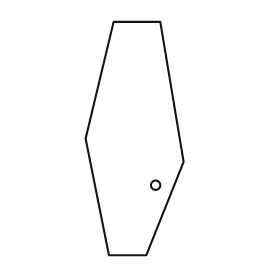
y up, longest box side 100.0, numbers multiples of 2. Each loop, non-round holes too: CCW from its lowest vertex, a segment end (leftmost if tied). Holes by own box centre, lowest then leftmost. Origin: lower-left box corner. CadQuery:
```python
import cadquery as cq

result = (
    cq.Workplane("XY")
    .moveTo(10.0, 0.0)
    .lineTo(26.0, 0.0)
    .lineTo(42.0, 40.0)
    .lineTo(32.0, 100.0)
    .lineTo(12.0, 100.0)
    .lineTo(0.0, 50.0)
    .close()
    .moveTo(30.0, 30.0)
    .circle(2.0)
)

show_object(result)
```